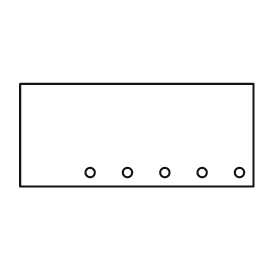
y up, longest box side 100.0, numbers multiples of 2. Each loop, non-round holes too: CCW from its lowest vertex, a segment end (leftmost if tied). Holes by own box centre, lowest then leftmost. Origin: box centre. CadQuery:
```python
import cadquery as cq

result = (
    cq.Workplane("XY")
    .moveTo(-50.0, -22.0)
    .lineTo(50.0, -22.0)
    .lineTo(50.0, 22.0)
    .lineTo(-50.0, 22.0)
    .close()
    .moveTo(-20.0, -16.0)
    .circle(2.0)
    .moveTo(-4.0, -16.0)
    .circle(2.0)
    .moveTo(12.0, -16.0)
    .circle(2.0)
    .moveTo(28.0, -16.0)
    .circle(2.0)
    .moveTo(44.0, -16.0)
    .circle(2.0)
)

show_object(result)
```